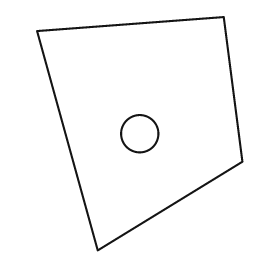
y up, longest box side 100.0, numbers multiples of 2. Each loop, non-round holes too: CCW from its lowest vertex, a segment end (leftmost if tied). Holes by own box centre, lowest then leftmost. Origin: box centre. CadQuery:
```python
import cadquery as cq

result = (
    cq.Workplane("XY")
    .moveTo(-18.0, -50.0)
    .lineTo(44.0, -12.0)
    .lineTo(36.0, 50.0)
    .lineTo(-44.0, 44.0)
    .close()
    .moveTo(0.0, 0.0)
    .circle(8.0)
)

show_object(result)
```